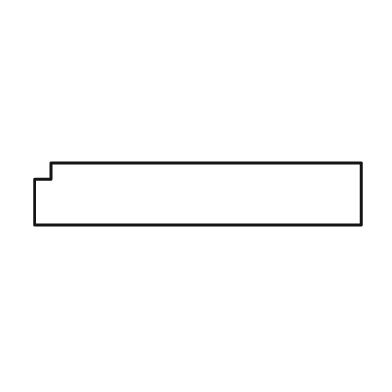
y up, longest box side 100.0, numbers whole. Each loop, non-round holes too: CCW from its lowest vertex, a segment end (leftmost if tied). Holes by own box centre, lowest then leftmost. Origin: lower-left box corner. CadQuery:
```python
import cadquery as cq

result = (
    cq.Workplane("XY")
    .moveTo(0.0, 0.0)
    .lineTo(100.0, 0.0)
    .lineTo(100.0, 19.0)
    .lineTo(5.0, 19.0)
    .lineTo(5.0, 14.0)
    .lineTo(0.0, 14.0)
    .close()
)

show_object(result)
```